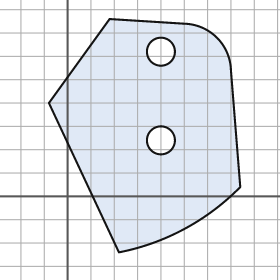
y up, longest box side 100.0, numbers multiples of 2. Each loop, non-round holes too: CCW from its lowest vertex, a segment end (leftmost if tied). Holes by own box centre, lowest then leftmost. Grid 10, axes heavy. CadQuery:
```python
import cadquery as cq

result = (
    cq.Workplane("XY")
    .moveTo(22.0, -24.0)
    .threePointArc((50.0, -14.0), (74.0, 4.0))
    .lineTo(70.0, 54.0)
    .threePointArc((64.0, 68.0), (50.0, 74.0))
    .lineTo(18.0, 76.0)
    .lineTo(-8.0, 40.0)
    .close()
    .moveTo(40.0, 24.0)
    .circle(6.0)
    .moveTo(40.0, 62.0)
    .circle(6.0)
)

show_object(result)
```